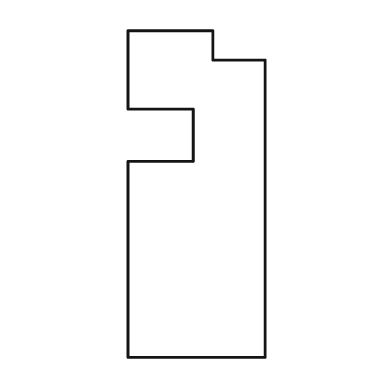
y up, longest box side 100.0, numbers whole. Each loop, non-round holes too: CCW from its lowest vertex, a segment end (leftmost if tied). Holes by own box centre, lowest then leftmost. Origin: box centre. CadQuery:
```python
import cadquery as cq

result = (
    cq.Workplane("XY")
    .moveTo(-21.0, -50.0)
    .lineTo(21.0, -50.0)
    .lineTo(21.0, 41.0)
    .lineTo(5.0, 41.0)
    .lineTo(5.0, 50.0)
    .lineTo(-21.0, 50.0)
    .lineTo(-21.0, 26.0)
    .lineTo(-1.0, 26.0)
    .lineTo(-1.0, 10.0)
    .lineTo(-21.0, 10.0)
    .close()
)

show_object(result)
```